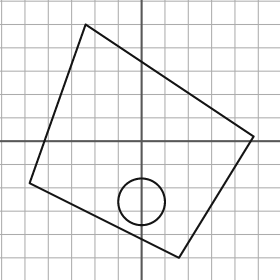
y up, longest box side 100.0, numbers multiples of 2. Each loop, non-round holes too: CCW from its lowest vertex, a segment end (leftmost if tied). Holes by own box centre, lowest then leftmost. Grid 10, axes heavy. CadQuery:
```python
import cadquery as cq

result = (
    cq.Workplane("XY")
    .moveTo(16.0, -50.0)
    .lineTo(48.0, 2.0)
    .lineTo(-24.0, 50.0)
    .lineTo(-48.0, -18.0)
    .close()
    .moveTo(0.0, -26.0)
    .circle(10.0)
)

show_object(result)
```